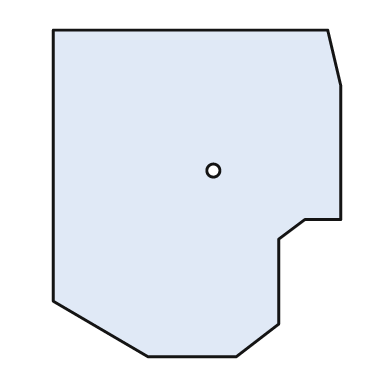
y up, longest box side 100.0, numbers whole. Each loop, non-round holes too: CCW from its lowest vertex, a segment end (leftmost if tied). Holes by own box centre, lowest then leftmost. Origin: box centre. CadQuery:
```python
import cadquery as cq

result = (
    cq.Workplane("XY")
    .moveTo(-15.0, -50.0)
    .lineTo(12.0, -50.0)
    .lineTo(25.0, -40.0)
    .lineTo(25.0, -14.0)
    .lineTo(33.0, -8.0)
    .lineTo(44.0, -8.0)
    .lineTo(44.0, 33.0)
    .lineTo(40.0, 50.0)
    .lineTo(-44.0, 50.0)
    .lineTo(-44.0, -33.0)
    .close()
    .moveTo(5.0, 7.0)
    .circle(2.0)
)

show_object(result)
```